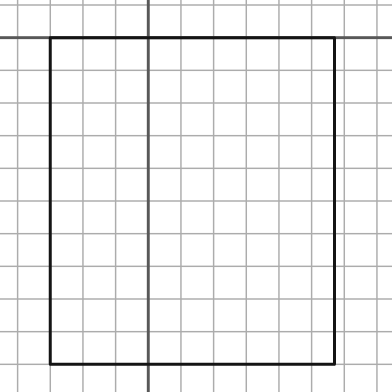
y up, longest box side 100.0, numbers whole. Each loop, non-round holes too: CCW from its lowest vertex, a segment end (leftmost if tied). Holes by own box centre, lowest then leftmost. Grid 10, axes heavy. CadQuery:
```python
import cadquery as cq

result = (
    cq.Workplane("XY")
    .moveTo(-30.0, -100.0)
    .lineTo(57.0, -100.0)
    .lineTo(57.0, 0.0)
    .lineTo(-30.0, 0.0)
    .close()
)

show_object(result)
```